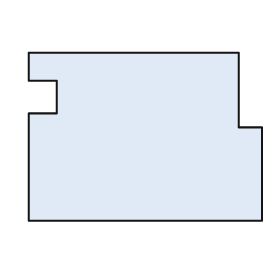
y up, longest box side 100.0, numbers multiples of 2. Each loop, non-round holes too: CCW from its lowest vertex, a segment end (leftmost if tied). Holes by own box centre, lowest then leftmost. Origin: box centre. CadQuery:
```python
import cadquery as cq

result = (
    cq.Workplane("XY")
    .moveTo(-50.0, -36.0)
    .lineTo(50.0, -36.0)
    .lineTo(50.0, 4.0)
    .lineTo(40.0, 4.0)
    .lineTo(40.0, 36.0)
    .lineTo(-50.0, 36.0)
    .lineTo(-50.0, 24.0)
    .lineTo(-38.0, 24.0)
    .lineTo(-38.0, 10.0)
    .lineTo(-50.0, 10.0)
    .close()
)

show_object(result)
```